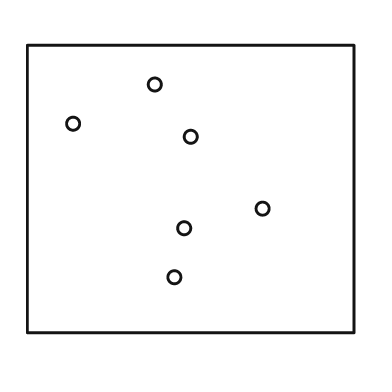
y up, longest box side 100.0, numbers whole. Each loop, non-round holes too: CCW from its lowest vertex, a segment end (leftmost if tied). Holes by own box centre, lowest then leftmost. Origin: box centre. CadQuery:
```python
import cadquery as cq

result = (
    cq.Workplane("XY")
    .moveTo(-50.0, -44.0)
    .lineTo(50.0, -44.0)
    .lineTo(50.0, 44.0)
    .lineTo(-50.0, 44.0)
    .close()
    .moveTo(-5.0, -27.0)
    .circle(2.0)
    .moveTo(-2.0, -12.0)
    .circle(2.0)
    .moveTo(22.0, -6.0)
    .circle(2.0)
    .moveTo(0.0, 16.0)
    .circle(2.0)
    .moveTo(-36.0, 20.0)
    .circle(2.0)
    .moveTo(-11.0, 32.0)
    .circle(2.0)
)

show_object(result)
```